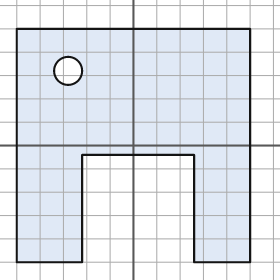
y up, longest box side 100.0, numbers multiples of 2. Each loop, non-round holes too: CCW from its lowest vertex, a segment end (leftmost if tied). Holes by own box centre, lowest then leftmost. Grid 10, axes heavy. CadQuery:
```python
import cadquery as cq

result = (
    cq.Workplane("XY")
    .moveTo(-50.0, -50.0)
    .lineTo(-22.0, -50.0)
    .lineTo(-22.0, -4.0)
    .lineTo(26.0, -4.0)
    .lineTo(26.0, -50.0)
    .lineTo(50.0, -50.0)
    .lineTo(50.0, 50.0)
    .lineTo(-50.0, 50.0)
    .close()
    .moveTo(-28.0, 32.0)
    .circle(6.0)
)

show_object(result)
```